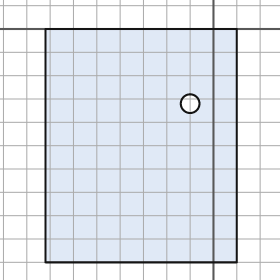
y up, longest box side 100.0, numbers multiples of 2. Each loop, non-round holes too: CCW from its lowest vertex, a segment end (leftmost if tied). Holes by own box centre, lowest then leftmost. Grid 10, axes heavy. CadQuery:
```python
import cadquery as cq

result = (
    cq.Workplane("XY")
    .moveTo(-72.0, -100.0)
    .lineTo(10.0, -100.0)
    .lineTo(10.0, 0.0)
    .lineTo(-72.0, 0.0)
    .close()
    .moveTo(-10.0, -32.0)
    .circle(4.0)
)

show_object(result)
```